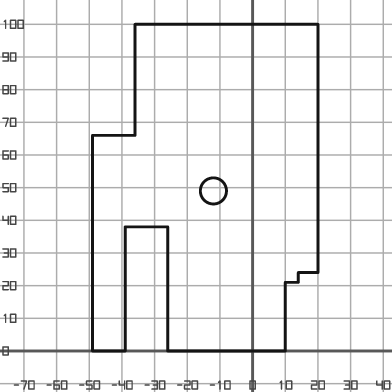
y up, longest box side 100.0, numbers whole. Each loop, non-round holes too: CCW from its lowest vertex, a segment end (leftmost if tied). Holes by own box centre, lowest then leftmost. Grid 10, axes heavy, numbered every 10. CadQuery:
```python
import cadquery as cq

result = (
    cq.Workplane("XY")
    .moveTo(-49.0, 0.0)
    .lineTo(-39.0, 0.0)
    .lineTo(-39.0, 38.0)
    .lineTo(-26.0, 38.0)
    .lineTo(-26.0, 0.0)
    .lineTo(10.0, 0.0)
    .lineTo(10.0, 21.0)
    .lineTo(14.0, 21.0)
    .lineTo(14.0, 24.0)
    .lineTo(20.0, 24.0)
    .lineTo(20.0, 100.0)
    .lineTo(-36.0, 100.0)
    .lineTo(-36.0, 66.0)
    .lineTo(-49.0, 66.0)
    .close()
    .moveTo(-12.0, 49.0)
    .circle(4.0)
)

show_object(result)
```